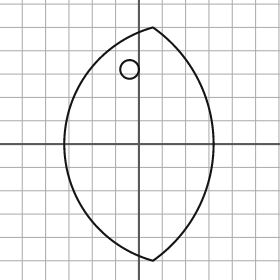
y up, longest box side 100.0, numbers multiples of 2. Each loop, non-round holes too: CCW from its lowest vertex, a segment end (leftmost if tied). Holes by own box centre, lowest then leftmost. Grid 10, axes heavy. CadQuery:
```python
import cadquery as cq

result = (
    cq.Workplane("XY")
    .moveTo(6.0, -50.0)
    .threePointArc((32.0, 0.0), (6.0, 50.0))
    .threePointArc((-32.0, 0.0), (6.0, -50.0))
    .close()
    .moveTo(-4.0, 32.0)
    .circle(4.0)
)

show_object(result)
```